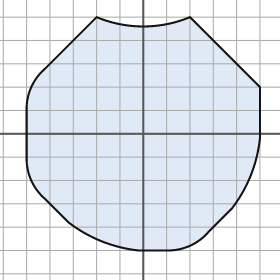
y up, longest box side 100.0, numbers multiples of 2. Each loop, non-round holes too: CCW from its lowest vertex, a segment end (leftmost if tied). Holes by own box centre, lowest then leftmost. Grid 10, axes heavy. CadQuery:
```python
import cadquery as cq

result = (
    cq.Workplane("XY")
    .moveTo(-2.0, -50.0)
    .lineTo(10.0, -50.0)
    .threePointArc((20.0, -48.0), (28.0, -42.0))
    .lineTo(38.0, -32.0)
    .threePointArc((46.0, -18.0), (50.0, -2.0))
    .lineTo(50.0, 20.0)
    .lineTo(20.0, 50.0)
    .threePointArc((0.0, 46.0), (-20.0, 50.0))
    .lineTo(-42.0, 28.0)
    .threePointArc((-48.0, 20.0), (-50.0, 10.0))
    .lineTo(-50.0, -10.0)
    .threePointArc((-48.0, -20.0), (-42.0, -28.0))
    .lineTo(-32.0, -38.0)
    .threePointArc((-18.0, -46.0), (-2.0, -50.0))
    .close()
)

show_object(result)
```